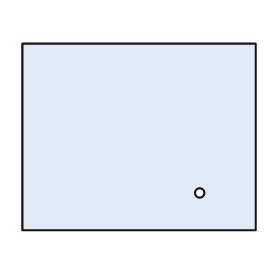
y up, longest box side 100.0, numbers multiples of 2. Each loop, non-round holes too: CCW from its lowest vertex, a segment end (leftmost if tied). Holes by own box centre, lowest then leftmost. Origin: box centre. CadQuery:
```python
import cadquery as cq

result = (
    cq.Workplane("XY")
    .moveTo(-50.0, -40.0)
    .lineTo(50.0, -40.0)
    .lineTo(50.0, 40.0)
    .lineTo(-50.0, 40.0)
    .close()
    .moveTo(26.0, -24.0)
    .circle(2.0)
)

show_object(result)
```